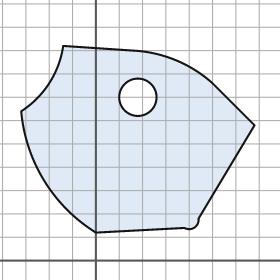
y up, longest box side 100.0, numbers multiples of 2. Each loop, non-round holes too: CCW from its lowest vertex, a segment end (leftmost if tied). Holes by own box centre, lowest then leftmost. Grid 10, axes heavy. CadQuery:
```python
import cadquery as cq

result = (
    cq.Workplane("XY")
    .moveTo(0.0, 12.0)
    .lineTo(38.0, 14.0)
    .threePointArc((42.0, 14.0), (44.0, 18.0))
    .lineTo(68.0, 58.0)
    .lineTo(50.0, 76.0)
    .threePointArc((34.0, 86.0), (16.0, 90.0))
    .lineTo(-14.0, 92.0)
    .threePointArc((-20.0, 76.0), (-32.0, 64.0))
    .threePointArc((-22.0, 34.0), (0.0, 12.0))
    .close()
    .moveTo(18.0, 70.0)
    .circle(8.0)
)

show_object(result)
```